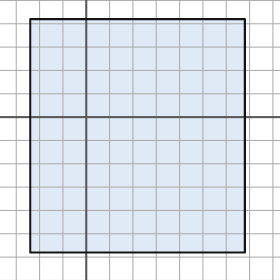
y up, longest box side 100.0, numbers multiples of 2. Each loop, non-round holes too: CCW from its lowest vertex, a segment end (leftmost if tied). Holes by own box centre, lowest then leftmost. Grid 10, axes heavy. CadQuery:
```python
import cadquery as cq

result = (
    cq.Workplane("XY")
    .moveTo(-24.0, -58.0)
    .lineTo(68.0, -58.0)
    .lineTo(68.0, 42.0)
    .lineTo(-24.0, 42.0)
    .close()
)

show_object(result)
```